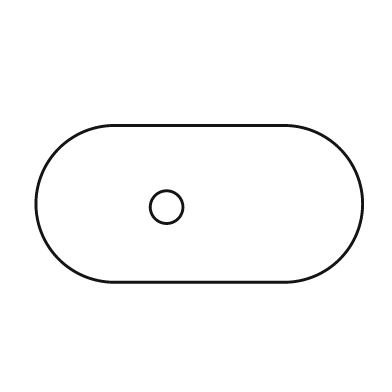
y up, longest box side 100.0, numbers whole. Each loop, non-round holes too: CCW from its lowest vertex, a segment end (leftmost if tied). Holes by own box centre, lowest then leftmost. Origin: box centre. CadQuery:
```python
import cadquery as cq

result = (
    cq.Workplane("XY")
    .moveTo(-26.0, -24.0)
    .lineTo(26.0, -24.0)
    .threePointArc((50.0, 0.0), (26.0, 24.0))
    .lineTo(-26.0, 24.0)
    .threePointArc((-50.0, 0.0), (-26.0, -24.0))
    .close()
    .moveTo(-10.0, -1.0)
    .circle(5.0)
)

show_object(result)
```